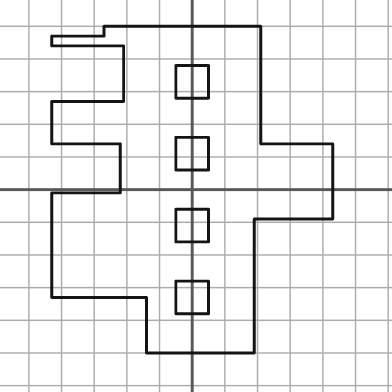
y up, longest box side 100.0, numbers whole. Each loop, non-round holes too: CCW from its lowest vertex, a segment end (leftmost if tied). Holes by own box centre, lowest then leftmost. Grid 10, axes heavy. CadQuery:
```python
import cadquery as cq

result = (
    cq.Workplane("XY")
    .moveTo(-14.0, -50.0)
    .lineTo(19.0, -50.0)
    .lineTo(19.0, -9.0)
    .lineTo(43.0, -9.0)
    .lineTo(43.0, 14.0)
    .lineTo(21.0, 14.0)
    .lineTo(21.0, 50.0)
    .lineTo(-27.0, 50.0)
    .lineTo(-27.0, 47.0)
    .lineTo(-43.0, 47.0)
    .lineTo(-43.0, 44.0)
    .lineTo(-21.0, 44.0)
    .lineTo(-21.0, 27.0)
    .lineTo(-43.0, 27.0)
    .lineTo(-43.0, 14.0)
    .lineTo(-22.0, 14.0)
    .lineTo(-22.0, -1.0)
    .lineTo(-43.0, -1.0)
    .lineTo(-43.0, -33.0)
    .lineTo(-14.0, -33.0)
    .close()
    .moveTo(-5.0, -38.0)
    .lineTo(5.0, -38.0)
    .lineTo(5.0, -28.0)
    .lineTo(-5.0, -28.0)
    .close()
    .moveTo(-5.0, -16.0)
    .lineTo(5.0, -16.0)
    .lineTo(5.0, -6.0)
    .lineTo(-5.0, -6.0)
    .close()
    .moveTo(-5.0, 6.0)
    .lineTo(5.0, 6.0)
    .lineTo(5.0, 16.0)
    .lineTo(-5.0, 16.0)
    .close()
    .moveTo(-5.0, 28.0)
    .lineTo(5.0, 28.0)
    .lineTo(5.0, 38.0)
    .lineTo(-5.0, 38.0)
    .close()
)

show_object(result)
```